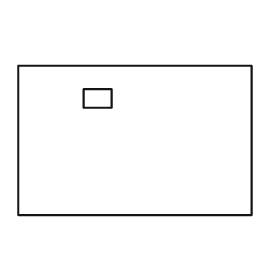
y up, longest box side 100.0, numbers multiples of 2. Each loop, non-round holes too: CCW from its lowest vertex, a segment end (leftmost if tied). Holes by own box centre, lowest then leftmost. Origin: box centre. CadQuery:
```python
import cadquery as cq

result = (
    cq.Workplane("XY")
    .moveTo(-50.0, -32.0)
    .lineTo(50.0, -32.0)
    .lineTo(50.0, 32.0)
    .lineTo(-50.0, 32.0)
    .close()
    .moveTo(-22.0, 14.0)
    .lineTo(-10.0, 14.0)
    .lineTo(-10.0, 22.0)
    .lineTo(-22.0, 22.0)
    .close()
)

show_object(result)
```